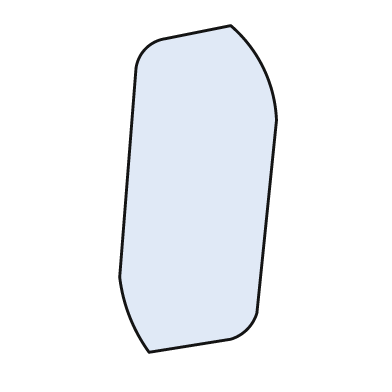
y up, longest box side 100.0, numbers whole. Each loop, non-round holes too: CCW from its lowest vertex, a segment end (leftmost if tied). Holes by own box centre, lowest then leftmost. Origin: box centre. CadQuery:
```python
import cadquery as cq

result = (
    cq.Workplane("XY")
    .moveTo(-15.0, -50.0)
    .lineTo(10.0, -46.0)
    .threePointArc((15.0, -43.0), (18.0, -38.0))
    .lineTo(24.0, 21.0)
    .threePointArc((20.0, 37.0), (10.0, 50.0))
    .lineTo(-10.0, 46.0)
    .threePointArc((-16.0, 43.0), (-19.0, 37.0))
    .lineTo(-24.0, -27.0)
    .threePointArc((-21.0, -39.0), (-15.0, -50.0))
    .close()
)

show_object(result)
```